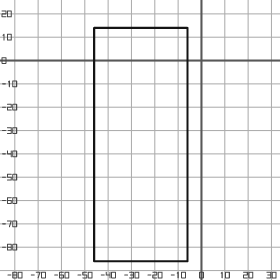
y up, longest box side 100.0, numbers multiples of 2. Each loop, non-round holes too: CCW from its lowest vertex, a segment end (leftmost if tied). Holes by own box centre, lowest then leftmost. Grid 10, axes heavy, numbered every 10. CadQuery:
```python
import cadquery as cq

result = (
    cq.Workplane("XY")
    .moveTo(-46.0, -86.0)
    .lineTo(-6.0, -86.0)
    .lineTo(-6.0, 14.0)
    .lineTo(-46.0, 14.0)
    .close()
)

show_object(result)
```